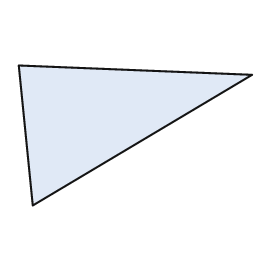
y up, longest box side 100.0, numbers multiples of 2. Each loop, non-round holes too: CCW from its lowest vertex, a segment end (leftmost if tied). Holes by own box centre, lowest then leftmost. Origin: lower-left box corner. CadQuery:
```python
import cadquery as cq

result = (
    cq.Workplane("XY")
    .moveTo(6.0, 0.0)
    .lineTo(100.0, 56.0)
    .lineTo(0.0, 60.0)
    .close()
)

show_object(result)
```